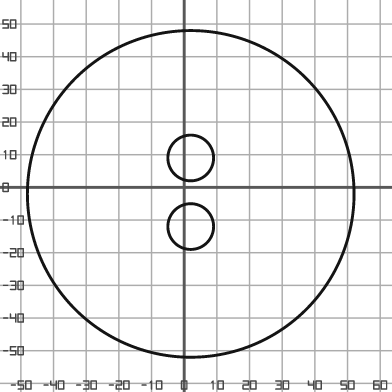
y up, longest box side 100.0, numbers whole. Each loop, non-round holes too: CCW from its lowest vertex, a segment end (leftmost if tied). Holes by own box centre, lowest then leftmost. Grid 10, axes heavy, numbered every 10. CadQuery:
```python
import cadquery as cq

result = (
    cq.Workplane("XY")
    .moveTo(2.0, -2.0)
    .circle(50.0)
    .moveTo(2.0, -12.0)
    .circle(7.0)
    .moveTo(2.0, 9.0)
    .circle(7.0)
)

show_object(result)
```